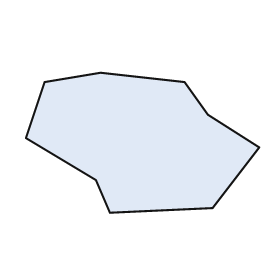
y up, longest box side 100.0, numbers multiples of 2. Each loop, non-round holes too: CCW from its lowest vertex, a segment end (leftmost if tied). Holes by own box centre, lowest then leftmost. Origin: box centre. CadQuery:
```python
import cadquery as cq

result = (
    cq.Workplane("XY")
    .moveTo(-14.0, -30.0)
    .lineTo(30.0, -28.0)
    .lineTo(50.0, -2.0)
    .lineTo(28.0, 12.0)
    .lineTo(18.0, 26.0)
    .lineTo(-18.0, 30.0)
    .lineTo(-42.0, 26.0)
    .lineTo(-50.0, 2.0)
    .lineTo(-20.0, -16.0)
    .close()
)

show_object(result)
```